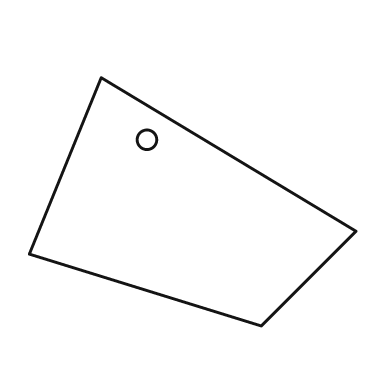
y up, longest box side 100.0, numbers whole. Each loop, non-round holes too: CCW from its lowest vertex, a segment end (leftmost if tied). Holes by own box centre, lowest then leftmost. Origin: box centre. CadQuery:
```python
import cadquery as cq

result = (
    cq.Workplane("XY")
    .moveTo(21.0, -38.0)
    .lineTo(50.0, -9.0)
    .lineTo(-28.0, 38.0)
    .lineTo(-50.0, -16.0)
    .close()
    .moveTo(-14.0, 19.0)
    .circle(3.0)
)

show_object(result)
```